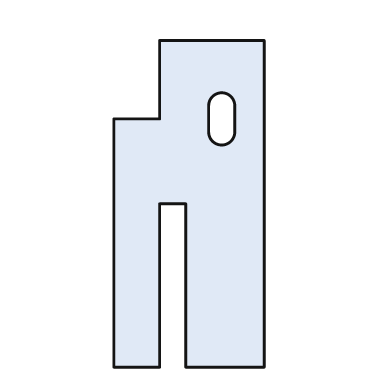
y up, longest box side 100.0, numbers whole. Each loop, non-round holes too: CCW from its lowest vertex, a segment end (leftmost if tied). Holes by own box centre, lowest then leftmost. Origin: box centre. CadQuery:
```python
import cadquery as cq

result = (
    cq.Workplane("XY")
    .moveTo(-23.0, -50.0)
    .lineTo(-9.0, -50.0)
    .lineTo(-9.0, 0.0)
    .lineTo(-1.0, 0.0)
    .lineTo(-1.0, -50.0)
    .lineTo(23.0, -50.0)
    .lineTo(23.0, 50.0)
    .lineTo(-9.0, 50.0)
    .lineTo(-9.0, 26.0)
    .lineTo(-23.0, 26.0)
    .close()
    .moveTo(6.0, 22.0)
    .threePointArc((10.0, 18.0), (14.0, 22.0))
    .lineTo(14.0, 30.0)
    .threePointArc((10.0, 34.0), (6.0, 30.0))
    .close()
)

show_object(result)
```